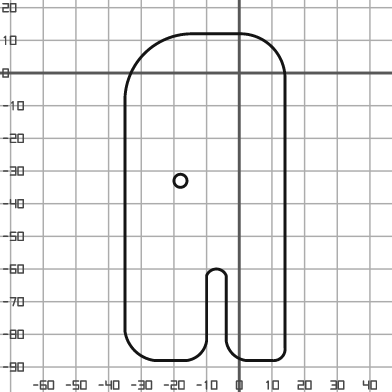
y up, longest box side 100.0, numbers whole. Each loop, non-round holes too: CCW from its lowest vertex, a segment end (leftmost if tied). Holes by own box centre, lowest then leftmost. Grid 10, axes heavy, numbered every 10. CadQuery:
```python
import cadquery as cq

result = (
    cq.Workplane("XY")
    .moveTo(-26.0, -88.0)
    .lineTo(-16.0, -88.0)
    .threePointArc((-12.0, -86.0), (-10.0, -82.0))
    .lineTo(-10.0, -62.0)
    .threePointArc((-7.0, -60.0), (-4.0, -62.0))
    .lineTo(-4.0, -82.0)
    .threePointArc((-2.0, -86.0), (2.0, -88.0))
    .lineTo(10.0, -88.0)
    .threePointArc((13.0, -87.0), (14.0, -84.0))
    .lineTo(14.0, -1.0)
    .threePointArc((10.0, 8.0), (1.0, 12.0))
    .lineTo(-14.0, 12.0)
    .threePointArc((-29.0, 6.0), (-35.0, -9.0))
    .lineTo(-35.0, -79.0)
    .threePointArc((-32.0, -85.0), (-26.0, -88.0))
    .close()
    .moveTo(-18.0, -33.0)
    .circle(2.0)
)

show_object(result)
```